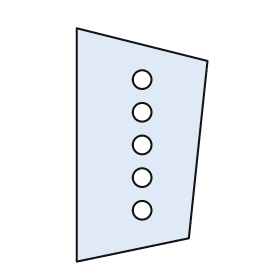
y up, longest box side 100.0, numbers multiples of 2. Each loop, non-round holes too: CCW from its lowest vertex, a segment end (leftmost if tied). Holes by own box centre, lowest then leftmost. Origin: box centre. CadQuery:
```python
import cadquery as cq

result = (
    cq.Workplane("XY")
    .moveTo(-28.0, -50.0)
    .lineTo(20.0, -40.0)
    .lineTo(28.0, 36.0)
    .lineTo(-28.0, 50.0)
    .close()
    .moveTo(0.0, -28.0)
    .circle(4.0)
    .moveTo(0.0, -14.0)
    .circle(4.0)
    .moveTo(0.0, 0.0)
    .circle(4.0)
    .moveTo(0.0, 14.0)
    .circle(4.0)
    .moveTo(0.0, 28.0)
    .circle(4.0)
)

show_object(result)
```